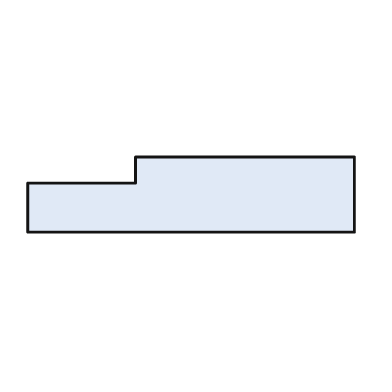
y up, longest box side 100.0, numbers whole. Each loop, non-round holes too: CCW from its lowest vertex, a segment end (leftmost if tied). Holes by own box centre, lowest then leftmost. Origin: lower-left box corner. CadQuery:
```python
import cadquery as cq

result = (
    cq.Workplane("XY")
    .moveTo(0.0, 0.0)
    .lineTo(100.0, 0.0)
    .lineTo(100.0, 23.0)
    .lineTo(33.0, 23.0)
    .lineTo(33.0, 15.0)
    .lineTo(0.0, 15.0)
    .close()
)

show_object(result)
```